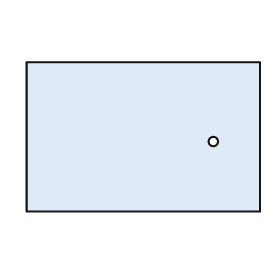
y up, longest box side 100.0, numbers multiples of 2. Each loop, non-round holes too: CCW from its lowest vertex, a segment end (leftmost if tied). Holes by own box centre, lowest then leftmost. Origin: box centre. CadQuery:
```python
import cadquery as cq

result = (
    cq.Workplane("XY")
    .moveTo(-50.0, -32.0)
    .lineTo(50.0, -32.0)
    .lineTo(50.0, 32.0)
    .lineTo(-50.0, 32.0)
    .close()
    .moveTo(30.0, -2.0)
    .circle(2.0)
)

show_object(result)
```